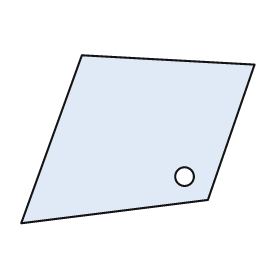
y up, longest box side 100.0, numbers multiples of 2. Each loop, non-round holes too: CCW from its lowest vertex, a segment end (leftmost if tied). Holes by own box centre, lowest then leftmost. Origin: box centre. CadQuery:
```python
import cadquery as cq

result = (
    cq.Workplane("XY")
    .moveTo(-50.0, -36.0)
    .lineTo(30.0, -26.0)
    .lineTo(50.0, 32.0)
    .lineTo(-24.0, 36.0)
    .close()
    .moveTo(20.0, -16.0)
    .circle(4.0)
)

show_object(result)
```